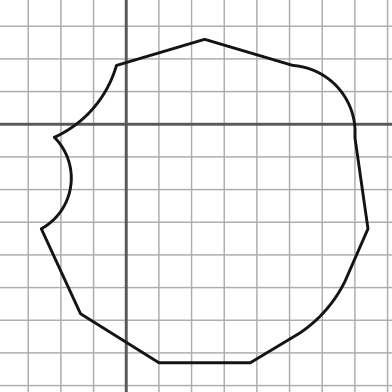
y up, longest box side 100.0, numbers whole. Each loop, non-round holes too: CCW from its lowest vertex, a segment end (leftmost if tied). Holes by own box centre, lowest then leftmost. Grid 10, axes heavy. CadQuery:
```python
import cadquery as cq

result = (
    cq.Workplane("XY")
    .moveTo(10.0, -73.0)
    .lineTo(38.0, -73.0)
    .lineTo(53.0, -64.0)
    .threePointArc((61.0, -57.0), (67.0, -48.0))
    .lineTo(74.0, -32.0)
    .lineTo(70.0, -4.0)
    .threePointArc((65.0, 11.0), (51.0, 18.0))
    .lineTo(24.0, 26.0)
    .lineTo(-3.0, 18.0)
    .threePointArc((-10.0, 5.0), (-22.0, -4.0))
    .threePointArc((-17.0, -19.0), (-26.0, -32.0))
    .lineTo(-14.0, -58.0)
    .close()
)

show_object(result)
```